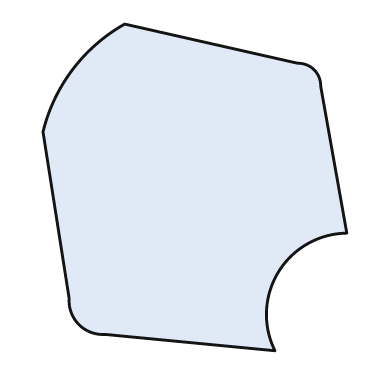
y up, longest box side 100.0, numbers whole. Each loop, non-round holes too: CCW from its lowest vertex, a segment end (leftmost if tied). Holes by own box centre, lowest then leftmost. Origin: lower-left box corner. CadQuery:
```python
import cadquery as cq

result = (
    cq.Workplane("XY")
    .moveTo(71.0, 0.0)
    .threePointArc((72.0, 24.0), (93.0, 36.0))
    .lineTo(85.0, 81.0)
    .threePointArc((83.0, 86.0), (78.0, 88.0))
    .lineTo(25.0, 100.0)
    .threePointArc((9.0, 86.0), (0.0, 67.0))
    .lineTo(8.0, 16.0)
    .threePointArc((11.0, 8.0), (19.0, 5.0))
    .close()
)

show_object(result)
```